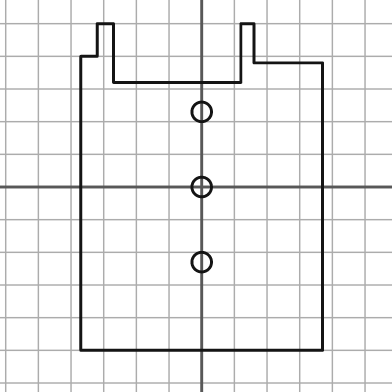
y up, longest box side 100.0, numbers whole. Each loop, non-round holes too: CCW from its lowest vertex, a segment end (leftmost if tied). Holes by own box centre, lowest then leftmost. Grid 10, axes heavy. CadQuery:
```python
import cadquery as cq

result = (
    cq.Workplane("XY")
    .moveTo(-37.0, -50.0)
    .lineTo(37.0, -50.0)
    .lineTo(37.0, 38.0)
    .lineTo(16.0, 38.0)
    .lineTo(16.0, 50.0)
    .lineTo(12.0, 50.0)
    .lineTo(12.0, 32.0)
    .lineTo(-27.0, 32.0)
    .lineTo(-27.0, 50.0)
    .lineTo(-32.0, 50.0)
    .lineTo(-32.0, 40.0)
    .lineTo(-37.0, 40.0)
    .close()
    .moveTo(0.0, -23.0)
    .circle(3.0)
    .moveTo(0.0, 0.0)
    .circle(3.0)
    .moveTo(0.0, 23.0)
    .circle(3.0)
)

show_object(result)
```